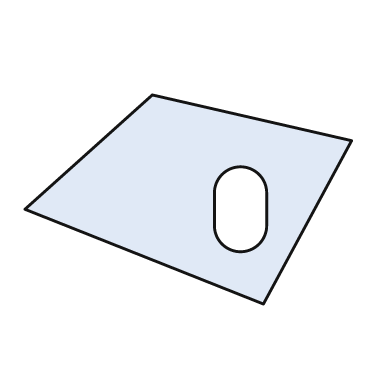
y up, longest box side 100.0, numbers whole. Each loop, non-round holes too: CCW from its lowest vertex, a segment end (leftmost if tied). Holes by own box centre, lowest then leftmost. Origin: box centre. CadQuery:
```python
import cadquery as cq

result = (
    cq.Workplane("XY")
    .moveTo(23.0, -32.0)
    .lineTo(50.0, 18.0)
    .lineTo(-11.0, 32.0)
    .lineTo(-50.0, -3.0)
    .close()
    .moveTo(8.0, -8.0)
    .threePointArc((16.0, -16.0), (24.0, -8.0))
    .lineTo(24.0, 2.0)
    .threePointArc((16.0, 10.0), (8.0, 2.0))
    .close()
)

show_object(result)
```